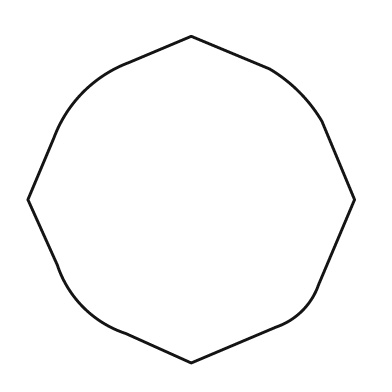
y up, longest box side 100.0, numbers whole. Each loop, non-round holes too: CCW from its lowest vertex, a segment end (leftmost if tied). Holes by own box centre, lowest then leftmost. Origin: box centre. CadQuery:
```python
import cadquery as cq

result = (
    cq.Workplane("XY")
    .moveTo(0.0, -50.0)
    .lineTo(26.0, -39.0)
    .threePointArc((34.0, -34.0), (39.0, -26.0))
    .lineTo(50.0, 0.0)
    .lineTo(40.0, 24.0)
    .threePointArc((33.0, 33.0), (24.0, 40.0))
    .lineTo(0.0, 50.0)
    .lineTo(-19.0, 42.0)
    .threePointArc((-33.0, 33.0), (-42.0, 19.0))
    .lineTo(-50.0, 0.0)
    .lineTo(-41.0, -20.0)
    .threePointArc((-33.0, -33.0), (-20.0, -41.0))
    .close()
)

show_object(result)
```